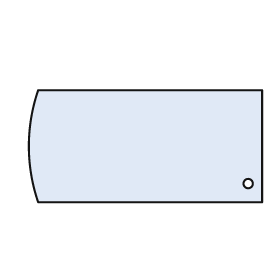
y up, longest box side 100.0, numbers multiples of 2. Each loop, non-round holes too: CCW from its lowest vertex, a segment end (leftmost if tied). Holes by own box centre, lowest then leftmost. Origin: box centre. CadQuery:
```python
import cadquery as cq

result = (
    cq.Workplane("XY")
    .moveTo(-46.0, -24.0)
    .lineTo(50.0, -24.0)
    .lineTo(50.0, 24.0)
    .lineTo(-46.0, 24.0)
    .threePointArc((-50.0, 0.0), (-46.0, -24.0))
    .close()
    .moveTo(44.0, -16.0)
    .circle(2.0)
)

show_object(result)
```